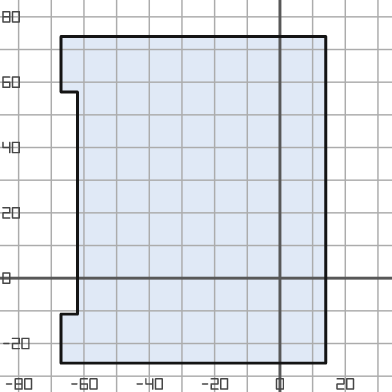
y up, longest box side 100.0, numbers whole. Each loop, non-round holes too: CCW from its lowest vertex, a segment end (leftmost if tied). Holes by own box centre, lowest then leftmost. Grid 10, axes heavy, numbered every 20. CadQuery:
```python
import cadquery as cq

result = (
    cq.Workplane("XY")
    .moveTo(-67.0, -26.0)
    .lineTo(14.0, -26.0)
    .lineTo(14.0, 74.0)
    .lineTo(-67.0, 74.0)
    .lineTo(-67.0, 57.0)
    .lineTo(-62.0, 57.0)
    .lineTo(-62.0, -11.0)
    .lineTo(-67.0, -11.0)
    .close()
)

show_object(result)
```